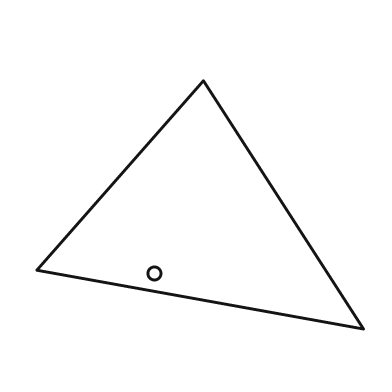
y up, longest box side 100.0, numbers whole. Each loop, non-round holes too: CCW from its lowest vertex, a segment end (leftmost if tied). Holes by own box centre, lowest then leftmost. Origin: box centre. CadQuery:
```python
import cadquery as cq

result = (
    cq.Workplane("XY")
    .moveTo(50.0, -38.0)
    .lineTo(1.0, 38.0)
    .lineTo(-50.0, -20.0)
    .close()
    .moveTo(-14.0, -21.0)
    .circle(2.0)
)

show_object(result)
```